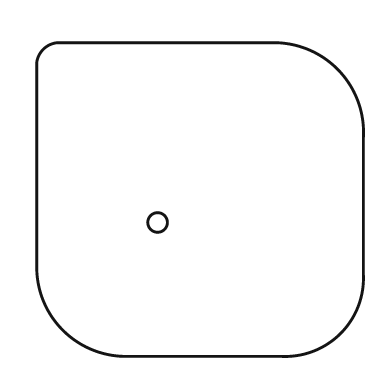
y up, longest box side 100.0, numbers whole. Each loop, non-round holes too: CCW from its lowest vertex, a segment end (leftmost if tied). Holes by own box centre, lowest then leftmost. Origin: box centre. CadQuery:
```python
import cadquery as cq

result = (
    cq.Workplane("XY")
    .moveTo(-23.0, -48.0)
    .lineTo(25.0, -48.0)
    .threePointArc((43.0, -41.0), (50.0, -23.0))
    .lineTo(50.0, 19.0)
    .threePointArc((42.0, 40.0), (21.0, 48.0))
    .lineTo(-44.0, 48.0)
    .threePointArc((-48.0, 46.0), (-50.0, 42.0))
    .lineTo(-50.0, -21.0)
    .threePointArc((-42.0, -40.0), (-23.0, -48.0))
    .close()
    .moveTo(-13.0, -7.0)
    .circle(3.0)
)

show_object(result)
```